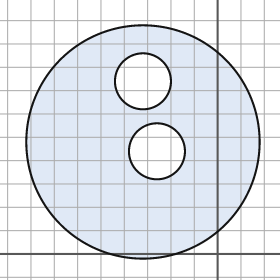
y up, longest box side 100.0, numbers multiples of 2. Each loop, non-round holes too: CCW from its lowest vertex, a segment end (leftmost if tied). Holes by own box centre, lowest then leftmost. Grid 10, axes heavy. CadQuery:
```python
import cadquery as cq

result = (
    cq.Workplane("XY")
    .moveTo(-32.0, 48.0)
    .circle(50.0)
    .moveTo(-26.0, 44.0)
    .circle(12.0)
    .moveTo(-32.0, 74.0)
    .circle(12.0)
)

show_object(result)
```